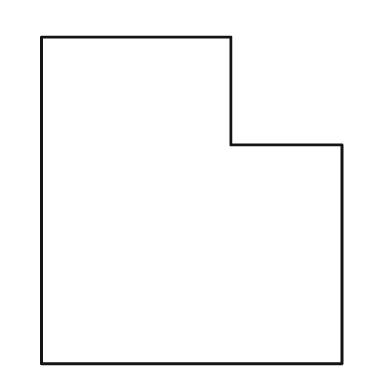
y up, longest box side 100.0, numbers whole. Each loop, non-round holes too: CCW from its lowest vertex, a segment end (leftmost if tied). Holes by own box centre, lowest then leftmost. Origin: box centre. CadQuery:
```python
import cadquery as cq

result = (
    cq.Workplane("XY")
    .moveTo(-46.0, -50.0)
    .lineTo(46.0, -50.0)
    .lineTo(46.0, 17.0)
    .lineTo(12.0, 17.0)
    .lineTo(12.0, 50.0)
    .lineTo(-46.0, 50.0)
    .close()
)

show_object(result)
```